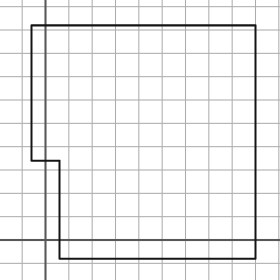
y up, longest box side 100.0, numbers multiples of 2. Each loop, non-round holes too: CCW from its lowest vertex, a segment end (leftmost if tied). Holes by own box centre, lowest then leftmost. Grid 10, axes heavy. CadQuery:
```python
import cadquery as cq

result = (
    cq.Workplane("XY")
    .moveTo(6.0, -8.0)
    .lineTo(90.0, -8.0)
    .lineTo(90.0, 92.0)
    .lineTo(-6.0, 92.0)
    .lineTo(-6.0, 34.0)
    .lineTo(6.0, 34.0)
    .close()
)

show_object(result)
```